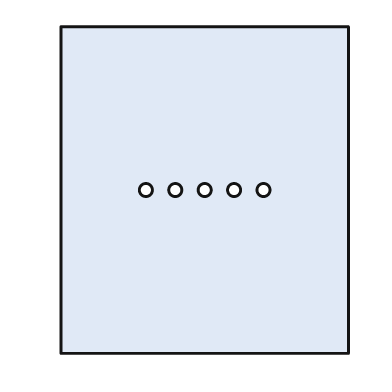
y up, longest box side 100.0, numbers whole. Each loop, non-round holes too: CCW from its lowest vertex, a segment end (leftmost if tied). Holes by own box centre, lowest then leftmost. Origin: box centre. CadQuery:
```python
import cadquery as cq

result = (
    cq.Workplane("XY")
    .moveTo(-44.0, -50.0)
    .lineTo(44.0, -50.0)
    .lineTo(44.0, 50.0)
    .lineTo(-44.0, 50.0)
    .close()
    .moveTo(-18.0, 0.0)
    .circle(2.0)
    .moveTo(-9.0, 0.0)
    .circle(2.0)
    .moveTo(0.0, 0.0)
    .circle(2.0)
    .moveTo(9.0, 0.0)
    .circle(2.0)
    .moveTo(18.0, 0.0)
    .circle(2.0)
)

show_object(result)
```